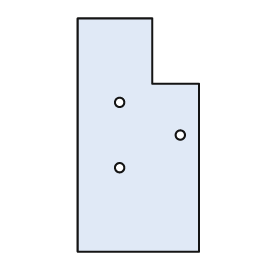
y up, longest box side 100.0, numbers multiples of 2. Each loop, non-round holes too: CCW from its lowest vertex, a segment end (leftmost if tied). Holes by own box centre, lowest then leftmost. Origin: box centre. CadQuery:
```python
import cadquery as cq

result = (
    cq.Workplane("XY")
    .moveTo(-26.0, -50.0)
    .lineTo(26.0, -50.0)
    .lineTo(26.0, 22.0)
    .lineTo(6.0, 22.0)
    .lineTo(6.0, 50.0)
    .lineTo(-26.0, 50.0)
    .close()
    .moveTo(-8.0, -14.0)
    .circle(2.0)
    .moveTo(18.0, 0.0)
    .circle(2.0)
    .moveTo(-8.0, 14.0)
    .circle(2.0)
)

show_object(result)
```